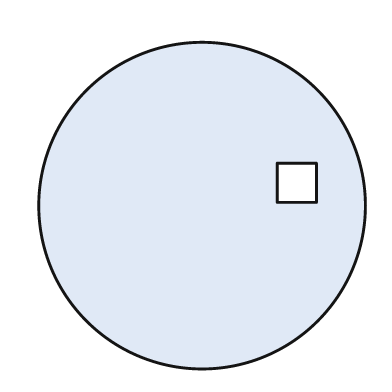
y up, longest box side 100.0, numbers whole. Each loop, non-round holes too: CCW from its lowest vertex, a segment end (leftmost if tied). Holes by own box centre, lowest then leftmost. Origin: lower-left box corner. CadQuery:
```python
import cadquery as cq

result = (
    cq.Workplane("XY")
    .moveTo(50.0, 50.0)
    .circle(50.0)
    .moveTo(73.0, 51.0)
    .lineTo(85.0, 51.0)
    .lineTo(85.0, 63.0)
    .lineTo(73.0, 63.0)
    .close()
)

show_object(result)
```